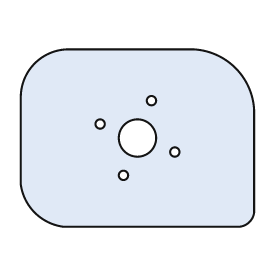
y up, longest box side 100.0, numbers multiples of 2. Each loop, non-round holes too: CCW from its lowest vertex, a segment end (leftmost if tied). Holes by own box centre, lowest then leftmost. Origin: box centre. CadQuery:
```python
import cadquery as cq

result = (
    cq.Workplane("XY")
    .moveTo(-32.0, -38.0)
    .lineTo(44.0, -38.0)
    .threePointArc((48.0, -36.0), (50.0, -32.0))
    .lineTo(50.0, 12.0)
    .threePointArc((42.0, 30.0), (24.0, 38.0))
    .lineTo(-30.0, 38.0)
    .threePointArc((-44.0, 32.0), (-50.0, 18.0))
    .lineTo(-50.0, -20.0)
    .threePointArc((-44.0, -32.0), (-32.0, -38.0))
    .close()
    .moveTo(-6.0, -16.0)
    .circle(2.0)
    .moveTo(16.0, -6.0)
    .circle(2.0)
    .moveTo(0.0, 0.0)
    .circle(8.0)
    .moveTo(-16.0, 6.0)
    .circle(2.0)
    .moveTo(6.0, 16.0)
    .circle(2.0)
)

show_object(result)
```